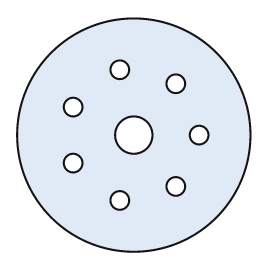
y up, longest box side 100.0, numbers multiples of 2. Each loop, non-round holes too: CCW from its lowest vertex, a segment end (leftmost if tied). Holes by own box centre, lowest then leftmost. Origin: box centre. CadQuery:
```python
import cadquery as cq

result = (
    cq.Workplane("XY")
    .moveTo(0.0, 0.0)
    .circle(50.0)
    .moveTo(-6.0, -28.0)
    .circle(4.0)
    .moveTo(18.0, -22.0)
    .circle(4.0)
    .moveTo(-26.0, -12.0)
    .circle(4.0)
    .moveTo(0.0, 0.0)
    .circle(8.0)
    .moveTo(28.0, 0.0)
    .circle(4.0)
    .moveTo(-26.0, 12.0)
    .circle(4.0)
    .moveTo(18.0, 22.0)
    .circle(4.0)
    .moveTo(-6.0, 28.0)
    .circle(4.0)
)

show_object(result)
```